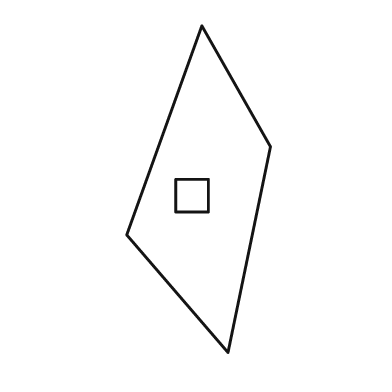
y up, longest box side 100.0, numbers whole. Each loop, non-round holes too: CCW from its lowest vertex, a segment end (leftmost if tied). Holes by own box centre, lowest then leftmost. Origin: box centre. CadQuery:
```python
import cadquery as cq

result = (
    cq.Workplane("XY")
    .moveTo(9.0, -50.0)
    .lineTo(22.0, 13.0)
    .lineTo(1.0, 50.0)
    .lineTo(-22.0, -14.0)
    .close()
    .moveTo(-7.0, -7.0)
    .lineTo(3.0, -7.0)
    .lineTo(3.0, 3.0)
    .lineTo(-7.0, 3.0)
    .close()
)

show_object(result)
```